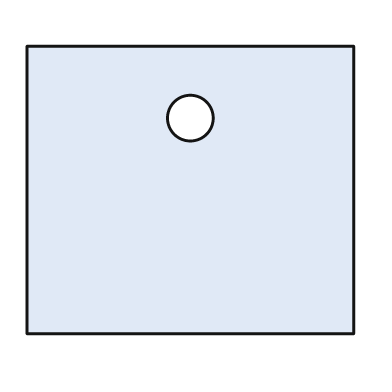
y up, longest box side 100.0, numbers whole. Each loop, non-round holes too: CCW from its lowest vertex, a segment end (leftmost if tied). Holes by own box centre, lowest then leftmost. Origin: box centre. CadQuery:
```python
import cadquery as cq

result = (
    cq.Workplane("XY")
    .moveTo(-50.0, -44.0)
    .lineTo(50.0, -44.0)
    .lineTo(50.0, 44.0)
    .lineTo(-50.0, 44.0)
    .close()
    .moveTo(0.0, 22.0)
    .circle(7.0)
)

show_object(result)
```